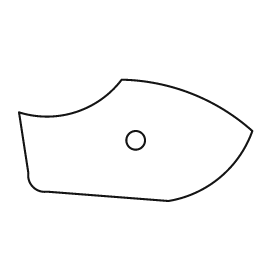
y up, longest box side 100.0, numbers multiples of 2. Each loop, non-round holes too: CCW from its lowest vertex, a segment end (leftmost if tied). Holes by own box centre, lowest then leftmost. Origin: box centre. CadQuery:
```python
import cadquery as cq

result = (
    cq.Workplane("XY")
    .moveTo(14.0, -26.0)
    .threePointArc((36.0, -16.0), (50.0, 4.0))
    .threePointArc((24.0, 20.0), (-6.0, 26.0))
    .threePointArc((-26.0, 12.0), (-50.0, 12.0))
    .lineTo(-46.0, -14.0)
    .threePointArc((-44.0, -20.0), (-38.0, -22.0))
    .close()
    .moveTo(0.0, 0.0)
    .circle(4.0)
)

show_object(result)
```